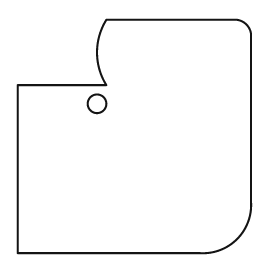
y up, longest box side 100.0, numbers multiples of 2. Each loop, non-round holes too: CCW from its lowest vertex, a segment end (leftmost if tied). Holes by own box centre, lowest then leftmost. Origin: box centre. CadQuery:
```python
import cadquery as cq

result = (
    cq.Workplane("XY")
    .moveTo(-50.0, -50.0)
    .lineTo(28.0, -50.0)
    .threePointArc((44.0, -44.0), (50.0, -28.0))
    .lineTo(50.0, 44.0)
    .threePointArc((48.0, 48.0), (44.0, 50.0))
    .lineTo(-12.0, 50.0)
    .threePointArc((-16.0, 36.0), (-12.0, 22.0))
    .lineTo(-50.0, 22.0)
    .close()
    .moveTo(-16.0, 14.0)
    .circle(4.0)
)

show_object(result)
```